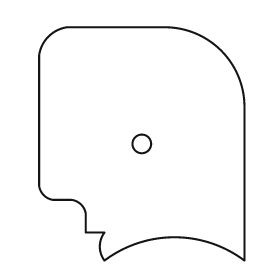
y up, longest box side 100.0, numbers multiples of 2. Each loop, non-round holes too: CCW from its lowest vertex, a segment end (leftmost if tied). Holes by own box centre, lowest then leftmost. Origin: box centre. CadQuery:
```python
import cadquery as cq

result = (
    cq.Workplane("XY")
    .moveTo(-16.0, -50.0)
    .threePointArc((14.0, -40.0), (44.0, -50.0))
    .lineTo(44.0, 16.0)
    .threePointArc((34.0, 40.0), (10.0, 50.0))
    .lineTo(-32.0, 50.0)
    .threePointArc((-40.0, 46.0), (-44.0, 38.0))
    .lineTo(-44.0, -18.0)
    .threePointArc((-42.0, -22.0), (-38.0, -24.0))
    .lineTo(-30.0, -24.0)
    .threePointArc((-26.0, -26.0), (-24.0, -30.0))
    .lineTo(-24.0, -38.0)
    .lineTo(-16.0, -38.0)
    .threePointArc((-18.0, -44.0), (-16.0, -50.0))
    .close()
    .moveTo(0.0, 0.0)
    .circle(4.0)
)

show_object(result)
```